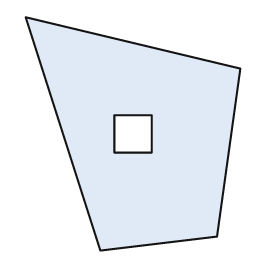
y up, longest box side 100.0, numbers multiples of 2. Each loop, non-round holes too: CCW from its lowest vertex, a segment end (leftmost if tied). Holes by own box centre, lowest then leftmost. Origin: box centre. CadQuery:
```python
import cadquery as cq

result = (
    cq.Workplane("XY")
    .moveTo(-14.0, -50.0)
    .lineTo(36.0, -44.0)
    .lineTo(46.0, 28.0)
    .lineTo(-46.0, 50.0)
    .close()
    .moveTo(-8.0, -8.0)
    .lineTo(8.0, -8.0)
    .lineTo(8.0, 8.0)
    .lineTo(-8.0, 8.0)
    .close()
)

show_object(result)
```